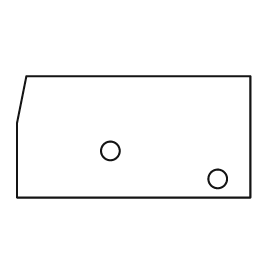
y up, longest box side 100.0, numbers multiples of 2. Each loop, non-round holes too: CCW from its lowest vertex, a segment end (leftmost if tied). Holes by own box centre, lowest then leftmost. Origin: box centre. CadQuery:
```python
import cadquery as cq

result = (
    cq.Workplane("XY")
    .moveTo(-50.0, -26.0)
    .lineTo(50.0, -26.0)
    .lineTo(50.0, 26.0)
    .lineTo(-46.0, 26.0)
    .lineTo(-50.0, 6.0)
    .close()
    .moveTo(36.0, -18.0)
    .circle(4.0)
    .moveTo(-10.0, -6.0)
    .circle(4.0)
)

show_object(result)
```